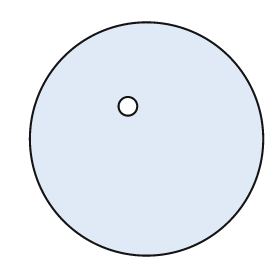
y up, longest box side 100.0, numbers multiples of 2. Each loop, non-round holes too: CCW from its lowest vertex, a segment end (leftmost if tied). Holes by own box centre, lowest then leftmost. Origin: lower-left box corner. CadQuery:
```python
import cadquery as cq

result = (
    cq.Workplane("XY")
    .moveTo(50.0, 50.0)
    .circle(50.0)
    .moveTo(42.0, 64.0)
    .circle(4.0)
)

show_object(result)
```